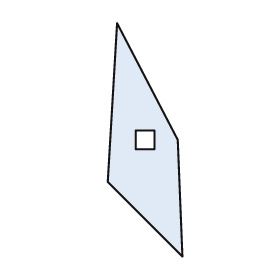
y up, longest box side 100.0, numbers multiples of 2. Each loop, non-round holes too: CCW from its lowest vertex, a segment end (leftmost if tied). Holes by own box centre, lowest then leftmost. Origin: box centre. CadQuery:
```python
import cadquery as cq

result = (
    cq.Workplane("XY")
    .moveTo(16.0, -50.0)
    .lineTo(14.0, 0.0)
    .lineTo(-12.0, 50.0)
    .lineTo(-16.0, -18.0)
    .close()
    .moveTo(-4.0, -4.0)
    .lineTo(4.0, -4.0)
    .lineTo(4.0, 4.0)
    .lineTo(-4.0, 4.0)
    .close()
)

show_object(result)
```